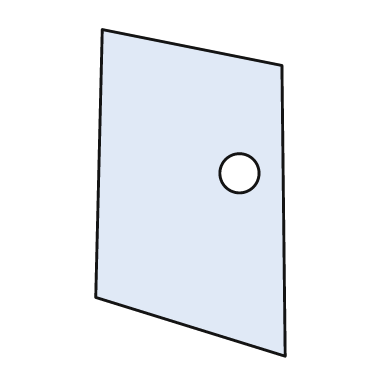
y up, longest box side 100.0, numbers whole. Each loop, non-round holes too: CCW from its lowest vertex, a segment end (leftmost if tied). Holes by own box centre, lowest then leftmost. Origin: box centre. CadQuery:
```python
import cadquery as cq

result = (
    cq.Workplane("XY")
    .moveTo(29.0, -50.0)
    .lineTo(28.0, 39.0)
    .lineTo(-27.0, 50.0)
    .lineTo(-29.0, -32.0)
    .close()
    .moveTo(15.0, 6.0)
    .circle(6.0)
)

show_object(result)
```